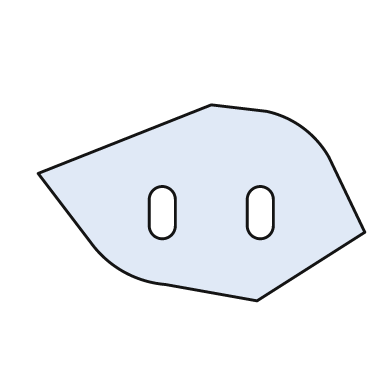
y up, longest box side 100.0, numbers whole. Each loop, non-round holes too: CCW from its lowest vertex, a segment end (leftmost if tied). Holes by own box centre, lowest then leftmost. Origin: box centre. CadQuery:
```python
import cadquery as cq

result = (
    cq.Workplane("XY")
    .moveTo(17.0, -30.0)
    .lineTo(50.0, -9.0)
    .lineTo(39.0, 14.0)
    .threePointArc((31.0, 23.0), (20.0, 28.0))
    .lineTo(3.0, 30.0)
    .lineTo(-50.0, 9.0)
    .lineTo(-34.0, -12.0)
    .threePointArc((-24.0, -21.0), (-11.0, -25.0))
    .close()
    .moveTo(-16.0, -7.0)
    .threePointArc((-12.0, -11.0), (-8.0, -7.0))
    .lineTo(-8.0, 1.0)
    .threePointArc((-12.0, 5.0), (-16.0, 1.0))
    .close()
    .moveTo(14.0, -7.0)
    .threePointArc((18.0, -11.0), (22.0, -7.0))
    .lineTo(22.0, 1.0)
    .threePointArc((18.0, 5.0), (14.0, 1.0))
    .close()
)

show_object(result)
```